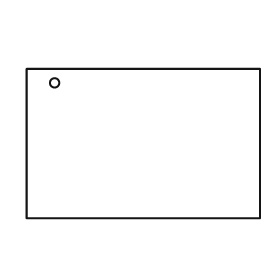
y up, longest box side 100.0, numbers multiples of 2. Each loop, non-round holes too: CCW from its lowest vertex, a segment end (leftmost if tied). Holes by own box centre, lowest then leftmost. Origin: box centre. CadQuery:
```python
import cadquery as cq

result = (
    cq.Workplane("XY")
    .moveTo(-50.0, -32.0)
    .lineTo(50.0, -32.0)
    .lineTo(50.0, 32.0)
    .lineTo(-50.0, 32.0)
    .close()
    .moveTo(-38.0, 26.0)
    .circle(2.0)
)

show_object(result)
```